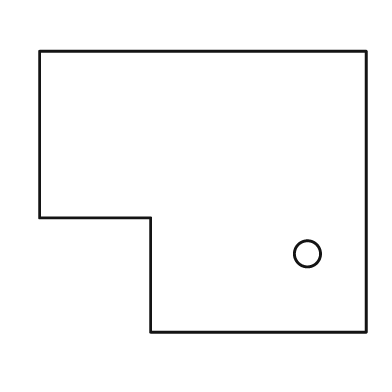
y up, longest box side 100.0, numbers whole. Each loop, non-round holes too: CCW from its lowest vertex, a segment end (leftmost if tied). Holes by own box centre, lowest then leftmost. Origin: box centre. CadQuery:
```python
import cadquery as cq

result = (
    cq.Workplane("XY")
    .moveTo(-16.0, -43.0)
    .lineTo(50.0, -43.0)
    .lineTo(50.0, 43.0)
    .lineTo(-50.0, 43.0)
    .lineTo(-50.0, -8.0)
    .lineTo(-16.0, -8.0)
    .close()
    .moveTo(32.0, -19.0)
    .circle(4.0)
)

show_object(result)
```